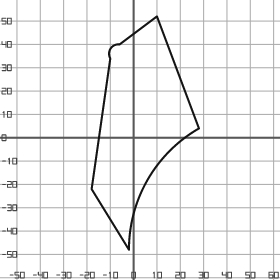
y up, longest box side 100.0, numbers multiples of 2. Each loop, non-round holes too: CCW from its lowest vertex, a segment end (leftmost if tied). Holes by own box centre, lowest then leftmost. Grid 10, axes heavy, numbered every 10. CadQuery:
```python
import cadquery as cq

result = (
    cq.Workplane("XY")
    .moveTo(-2.0, -48.0)
    .threePointArc((6.0, -18.0), (28.0, 4.0))
    .lineTo(10.0, 52.0)
    .lineTo(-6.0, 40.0)
    .threePointArc((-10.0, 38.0), (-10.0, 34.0))
    .lineTo(-18.0, -22.0)
    .close()
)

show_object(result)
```